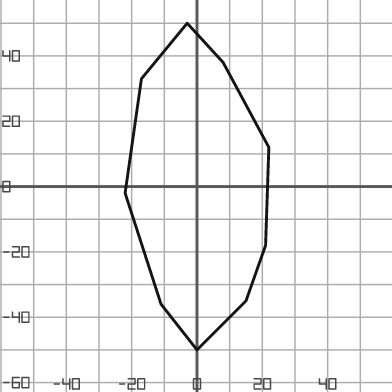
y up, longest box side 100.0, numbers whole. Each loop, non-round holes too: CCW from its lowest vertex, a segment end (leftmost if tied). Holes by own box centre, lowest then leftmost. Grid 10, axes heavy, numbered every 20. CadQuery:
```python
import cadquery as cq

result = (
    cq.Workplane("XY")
    .moveTo(0.0, -50.0)
    .lineTo(15.0, -35.0)
    .lineTo(21.0, -18.0)
    .lineTo(22.0, 12.0)
    .lineTo(8.0, 38.0)
    .lineTo(-3.0, 50.0)
    .lineTo(-17.0, 33.0)
    .lineTo(-22.0, -2.0)
    .lineTo(-11.0, -36.0)
    .close()
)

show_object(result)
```